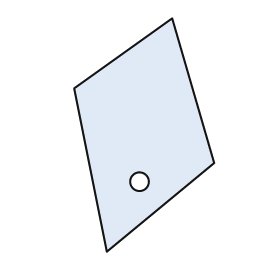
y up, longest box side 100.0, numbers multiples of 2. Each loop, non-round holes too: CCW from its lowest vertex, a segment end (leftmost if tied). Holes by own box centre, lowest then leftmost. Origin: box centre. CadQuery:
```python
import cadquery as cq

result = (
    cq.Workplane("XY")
    .moveTo(-16.0, -50.0)
    .lineTo(30.0, -12.0)
    .lineTo(12.0, 50.0)
    .lineTo(-30.0, 20.0)
    .close()
    .moveTo(-2.0, -20.0)
    .circle(4.0)
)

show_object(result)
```